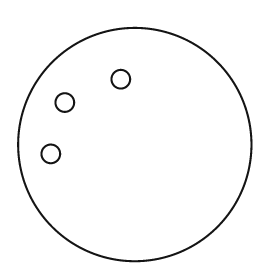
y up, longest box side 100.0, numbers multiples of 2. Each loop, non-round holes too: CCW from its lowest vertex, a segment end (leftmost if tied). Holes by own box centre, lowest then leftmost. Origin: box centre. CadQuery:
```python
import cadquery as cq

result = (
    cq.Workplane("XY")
    .moveTo(0.0, 0.0)
    .circle(50.0)
    .moveTo(-36.0, -4.0)
    .circle(4.0)
    .moveTo(-30.0, 18.0)
    .circle(4.0)
    .moveTo(-6.0, 28.0)
    .circle(4.0)
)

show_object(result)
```